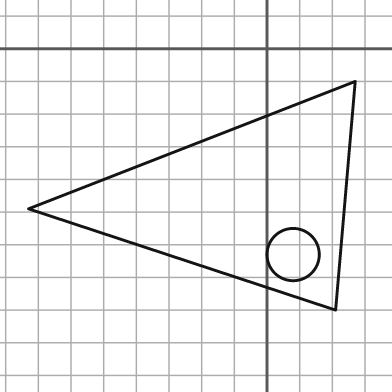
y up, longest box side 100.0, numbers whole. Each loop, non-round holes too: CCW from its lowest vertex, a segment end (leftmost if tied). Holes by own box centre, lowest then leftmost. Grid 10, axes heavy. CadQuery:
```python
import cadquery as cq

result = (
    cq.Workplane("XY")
    .moveTo(21.0, -80.0)
    .lineTo(27.0, -10.0)
    .lineTo(-73.0, -49.0)
    .close()
    .moveTo(8.0, -63.0)
    .circle(8.0)
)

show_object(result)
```